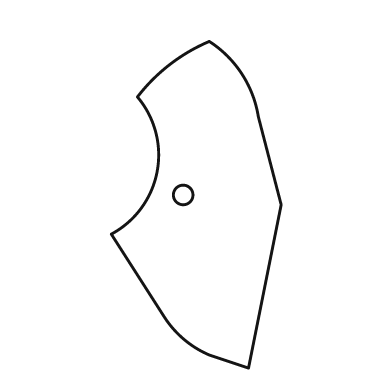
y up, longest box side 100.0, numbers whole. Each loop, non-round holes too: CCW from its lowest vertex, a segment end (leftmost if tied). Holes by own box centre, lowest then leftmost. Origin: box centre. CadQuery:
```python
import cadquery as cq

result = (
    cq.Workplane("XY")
    .moveTo(16.0, -50.0)
    .lineTo(26.0, 0.0)
    .lineTo(19.0, 27.0)
    .threePointArc((14.0, 40.0), (4.0, 50.0))
    .threePointArc((-8.0, 43.0), (-18.0, 33.0))
    .threePointArc((-12.0, 10.0), (-26.0, -9.0))
    .lineTo(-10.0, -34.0)
    .threePointArc((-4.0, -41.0), (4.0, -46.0))
    .close()
    .moveTo(-4.0, 3.0)
    .circle(3.0)
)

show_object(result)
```